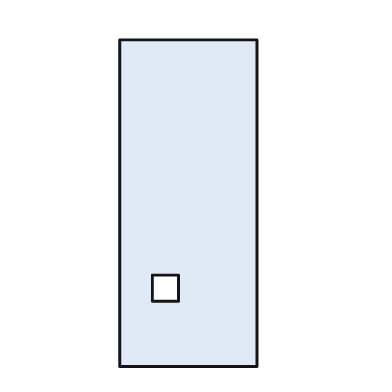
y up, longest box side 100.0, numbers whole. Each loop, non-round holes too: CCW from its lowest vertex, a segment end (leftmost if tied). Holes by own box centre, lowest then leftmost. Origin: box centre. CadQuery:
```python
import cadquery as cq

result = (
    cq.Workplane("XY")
    .moveTo(-21.0, -50.0)
    .lineTo(21.0, -50.0)
    .lineTo(21.0, 50.0)
    .lineTo(-21.0, 50.0)
    .close()
    .moveTo(-11.0, -30.0)
    .lineTo(-3.0, -30.0)
    .lineTo(-3.0, -22.0)
    .lineTo(-11.0, -22.0)
    .close()
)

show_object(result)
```